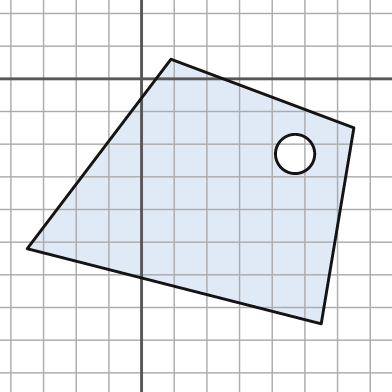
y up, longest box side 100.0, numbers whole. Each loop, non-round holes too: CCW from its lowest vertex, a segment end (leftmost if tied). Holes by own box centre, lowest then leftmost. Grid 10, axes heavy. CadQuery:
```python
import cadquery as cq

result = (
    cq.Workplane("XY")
    .moveTo(55.0, -75.0)
    .lineTo(65.0, -15.0)
    .lineTo(9.0, 6.0)
    .lineTo(-35.0, -52.0)
    .close()
    .moveTo(47.0, -23.0)
    .circle(6.0)
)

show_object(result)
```